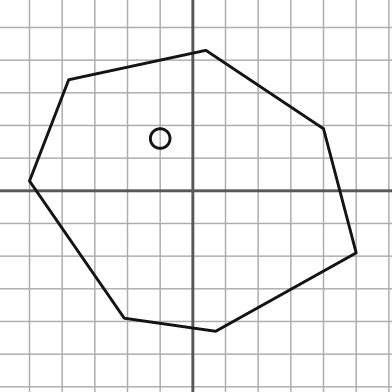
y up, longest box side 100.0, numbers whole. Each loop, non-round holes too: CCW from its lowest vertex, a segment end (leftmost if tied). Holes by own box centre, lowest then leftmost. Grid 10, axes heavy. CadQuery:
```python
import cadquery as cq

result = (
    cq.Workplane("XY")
    .moveTo(7.0, -43.0)
    .lineTo(50.0, -19.0)
    .lineTo(40.0, 19.0)
    .lineTo(4.0, 43.0)
    .lineTo(-38.0, 34.0)
    .lineTo(-50.0, 3.0)
    .lineTo(-21.0, -39.0)
    .close()
    .moveTo(-10.0, 16.0)
    .circle(3.0)
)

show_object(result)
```